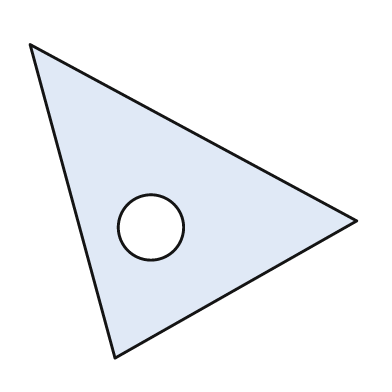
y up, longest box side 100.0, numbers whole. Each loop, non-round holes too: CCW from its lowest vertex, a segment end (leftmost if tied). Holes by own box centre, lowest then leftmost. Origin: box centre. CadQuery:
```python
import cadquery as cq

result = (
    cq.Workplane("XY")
    .moveTo(-24.0, -48.0)
    .lineTo(50.0, -6.0)
    .lineTo(-50.0, 48.0)
    .close()
    .moveTo(-13.0, -8.0)
    .circle(10.0)
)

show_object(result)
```